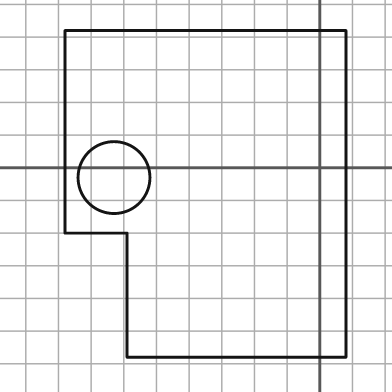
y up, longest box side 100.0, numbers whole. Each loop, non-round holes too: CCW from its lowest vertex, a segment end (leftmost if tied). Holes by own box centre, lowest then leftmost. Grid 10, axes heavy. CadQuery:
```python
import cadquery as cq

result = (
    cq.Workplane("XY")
    .moveTo(-59.0, -58.0)
    .lineTo(8.0, -58.0)
    .lineTo(8.0, 42.0)
    .lineTo(-78.0, 42.0)
    .lineTo(-78.0, -20.0)
    .lineTo(-59.0, -20.0)
    .close()
    .moveTo(-63.0, -3.0)
    .circle(11.0)
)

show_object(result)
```